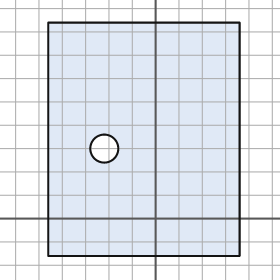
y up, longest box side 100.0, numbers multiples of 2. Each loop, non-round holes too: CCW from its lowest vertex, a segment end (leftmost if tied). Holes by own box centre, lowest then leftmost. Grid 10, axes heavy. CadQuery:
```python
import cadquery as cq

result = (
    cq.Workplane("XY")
    .moveTo(-46.0, -16.0)
    .lineTo(36.0, -16.0)
    .lineTo(36.0, 84.0)
    .lineTo(-46.0, 84.0)
    .close()
    .moveTo(-22.0, 30.0)
    .circle(6.0)
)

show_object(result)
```